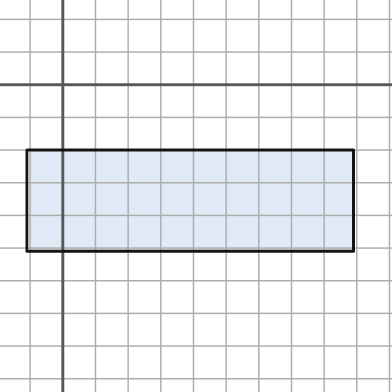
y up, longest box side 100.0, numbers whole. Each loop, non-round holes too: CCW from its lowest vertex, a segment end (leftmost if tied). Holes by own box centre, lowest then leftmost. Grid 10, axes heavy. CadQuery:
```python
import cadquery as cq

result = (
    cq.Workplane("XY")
    .moveTo(-11.0, -51.0)
    .lineTo(89.0, -51.0)
    .lineTo(89.0, -20.0)
    .lineTo(-11.0, -20.0)
    .close()
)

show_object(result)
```